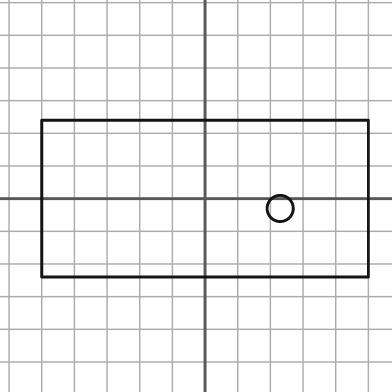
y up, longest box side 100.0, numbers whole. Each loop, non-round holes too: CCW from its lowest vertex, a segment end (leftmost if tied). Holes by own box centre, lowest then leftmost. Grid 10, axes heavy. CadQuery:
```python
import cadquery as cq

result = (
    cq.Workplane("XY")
    .moveTo(-50.0, -24.0)
    .lineTo(50.0, -24.0)
    .lineTo(50.0, 24.0)
    .lineTo(-50.0, 24.0)
    .close()
    .moveTo(23.0, -3.0)
    .circle(4.0)
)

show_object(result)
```